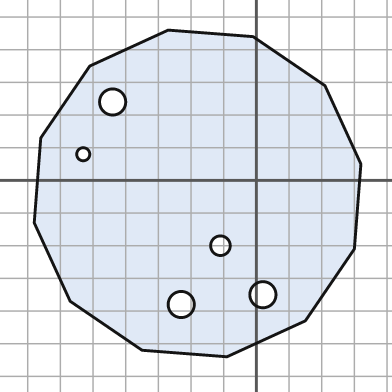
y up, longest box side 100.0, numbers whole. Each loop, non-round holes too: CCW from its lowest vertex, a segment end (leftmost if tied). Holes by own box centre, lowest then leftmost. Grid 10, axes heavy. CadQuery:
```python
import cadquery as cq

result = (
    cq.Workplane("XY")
    .moveTo(-9.0, -54.0)
    .lineTo(15.0, -43.0)
    .lineTo(30.0, -21.0)
    .lineTo(32.0, 5.0)
    .lineTo(21.0, 29.0)
    .lineTo(-1.0, 44.0)
    .lineTo(-27.0, 46.0)
    .lineTo(-51.0, 35.0)
    .lineTo(-66.0, 13.0)
    .lineTo(-68.0, -13.0)
    .lineTo(-57.0, -37.0)
    .lineTo(-35.0, -52.0)
    .close()
    .moveTo(-23.0, -38.0)
    .circle(4.0)
    .moveTo(2.0, -35.0)
    .circle(4.0)
    .moveTo(-11.0, -20.0)
    .circle(3.0)
    .moveTo(-53.0, 8.0)
    .circle(2.0)
    .moveTo(-44.0, 24.0)
    .circle(4.0)
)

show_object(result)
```